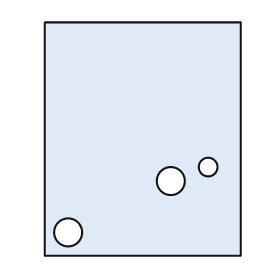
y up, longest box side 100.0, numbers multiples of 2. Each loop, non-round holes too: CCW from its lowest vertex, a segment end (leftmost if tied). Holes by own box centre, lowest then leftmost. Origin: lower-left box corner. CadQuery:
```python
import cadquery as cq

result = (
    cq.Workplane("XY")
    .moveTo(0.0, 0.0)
    .lineTo(84.0, 0.0)
    .lineTo(84.0, 100.0)
    .lineTo(0.0, 100.0)
    .close()
    .moveTo(10.0, 10.0)
    .circle(6.0)
    .moveTo(54.0, 32.0)
    .circle(6.0)
    .moveTo(70.0, 38.0)
    .circle(4.0)
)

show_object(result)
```